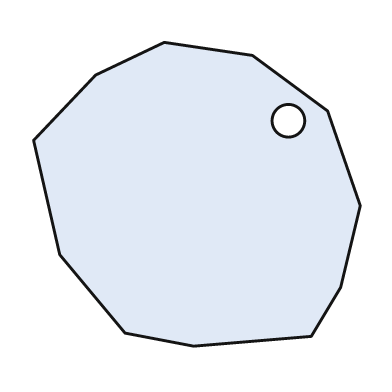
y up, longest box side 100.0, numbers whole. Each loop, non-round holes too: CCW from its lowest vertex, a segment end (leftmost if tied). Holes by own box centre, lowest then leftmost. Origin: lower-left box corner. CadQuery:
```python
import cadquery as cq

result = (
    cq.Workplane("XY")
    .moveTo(49.0, 0.0)
    .lineTo(85.0, 3.0)
    .lineTo(94.0, 18.0)
    .lineTo(100.0, 43.0)
    .lineTo(90.0, 72.0)
    .lineTo(67.0, 89.0)
    .lineTo(40.0, 93.0)
    .lineTo(19.0, 83.0)
    .lineTo(0.0, 63.0)
    .lineTo(8.0, 28.0)
    .lineTo(28.0, 4.0)
    .close()
    .moveTo(78.0, 69.0)
    .circle(5.0)
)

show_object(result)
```